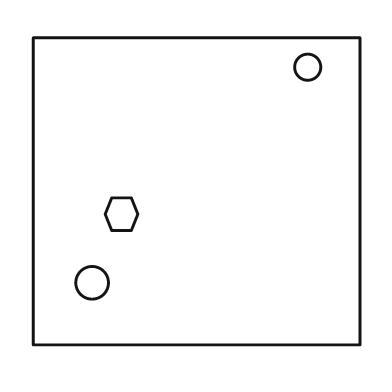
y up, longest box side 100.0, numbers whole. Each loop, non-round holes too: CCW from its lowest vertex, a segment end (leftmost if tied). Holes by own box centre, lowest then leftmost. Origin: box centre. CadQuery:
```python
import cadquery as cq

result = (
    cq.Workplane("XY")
    .moveTo(-50.0, -47.0)
    .lineTo(50.0, -47.0)
    .lineTo(50.0, 47.0)
    .lineTo(-50.0, 47.0)
    .close()
    .moveTo(-32.0, -28.0)
    .circle(5.0)
    .moveTo(-26.0, -12.0)
    .lineTo(-20.0, -12.0)
    .lineTo(-18.0, -7.0)
    .lineTo(-20.0, -2.0)
    .lineTo(-26.0, -2.0)
    .lineTo(-28.0, -7.0)
    .close()
    .moveTo(34.0, 38.0)
    .circle(4.0)
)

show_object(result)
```